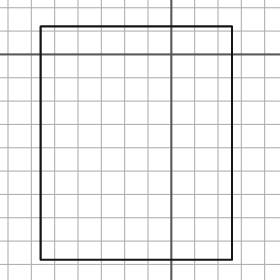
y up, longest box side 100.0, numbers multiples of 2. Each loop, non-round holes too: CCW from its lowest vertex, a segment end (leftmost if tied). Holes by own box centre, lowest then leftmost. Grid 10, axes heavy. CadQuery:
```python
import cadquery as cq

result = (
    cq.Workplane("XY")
    .moveTo(-56.0, -88.0)
    .lineTo(26.0, -88.0)
    .lineTo(26.0, 12.0)
    .lineTo(-56.0, 12.0)
    .close()
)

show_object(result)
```